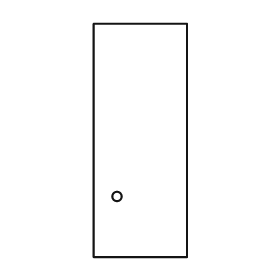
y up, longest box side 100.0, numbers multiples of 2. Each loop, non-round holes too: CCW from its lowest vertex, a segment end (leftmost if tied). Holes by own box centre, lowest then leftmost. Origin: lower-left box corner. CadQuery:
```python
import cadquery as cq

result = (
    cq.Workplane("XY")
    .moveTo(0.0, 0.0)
    .lineTo(40.0, 0.0)
    .lineTo(40.0, 100.0)
    .lineTo(0.0, 100.0)
    .close()
    .moveTo(10.0, 26.0)
    .circle(2.0)
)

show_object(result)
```